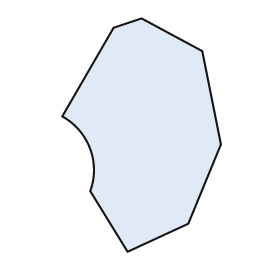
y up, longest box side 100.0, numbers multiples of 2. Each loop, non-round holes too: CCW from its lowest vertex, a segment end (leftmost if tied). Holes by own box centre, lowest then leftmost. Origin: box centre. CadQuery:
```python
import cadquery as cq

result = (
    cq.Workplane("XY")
    .moveTo(-6.0, -50.0)
    .lineTo(20.0, -38.0)
    .lineTo(34.0, -4.0)
    .lineTo(26.0, 36.0)
    .lineTo(0.0, 50.0)
    .lineTo(-12.0, 46.0)
    .lineTo(-34.0, 8.0)
    .threePointArc((-22.0, -6.0), (-22.0, -24.0))
    .close()
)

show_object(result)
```